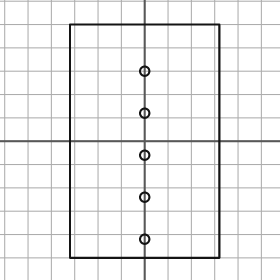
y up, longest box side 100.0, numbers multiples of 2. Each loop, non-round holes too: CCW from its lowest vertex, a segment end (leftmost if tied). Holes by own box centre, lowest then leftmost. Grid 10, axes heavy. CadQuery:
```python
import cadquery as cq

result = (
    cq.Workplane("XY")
    .moveTo(-32.0, -50.0)
    .lineTo(32.0, -50.0)
    .lineTo(32.0, 50.0)
    .lineTo(-32.0, 50.0)
    .close()
    .moveTo(0.0, -42.0)
    .circle(2.0)
    .moveTo(0.0, -24.0)
    .circle(2.0)
    .moveTo(0.0, -6.0)
    .circle(2.0)
    .moveTo(0.0, 12.0)
    .circle(2.0)
    .moveTo(0.0, 30.0)
    .circle(2.0)
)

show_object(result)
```